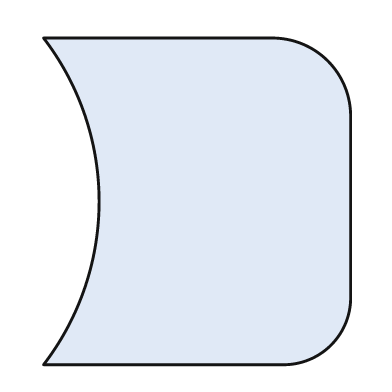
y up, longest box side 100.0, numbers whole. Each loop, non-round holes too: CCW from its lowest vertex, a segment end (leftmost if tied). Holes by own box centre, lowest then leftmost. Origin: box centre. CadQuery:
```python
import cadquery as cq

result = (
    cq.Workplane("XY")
    .moveTo(-47.0, -50.0)
    .lineTo(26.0, -50.0)
    .threePointArc((41.0, -44.0), (47.0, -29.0))
    .lineTo(47.0, 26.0)
    .threePointArc((40.0, 43.0), (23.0, 50.0))
    .lineTo(-47.0, 50.0)
    .threePointArc((-30.0, 0.0), (-47.0, -50.0))
    .close()
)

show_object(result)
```